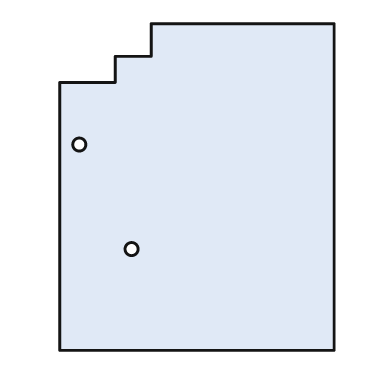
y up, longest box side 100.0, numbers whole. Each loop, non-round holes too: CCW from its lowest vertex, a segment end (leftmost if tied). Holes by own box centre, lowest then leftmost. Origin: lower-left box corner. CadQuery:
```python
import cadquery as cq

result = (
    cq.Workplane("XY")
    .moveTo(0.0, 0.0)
    .lineTo(84.0, 0.0)
    .lineTo(84.0, 100.0)
    .lineTo(28.0, 100.0)
    .lineTo(28.0, 90.0)
    .lineTo(17.0, 90.0)
    .lineTo(17.0, 82.0)
    .lineTo(0.0, 82.0)
    .close()
    .moveTo(22.0, 31.0)
    .circle(2.0)
    .moveTo(6.0, 63.0)
    .circle(2.0)
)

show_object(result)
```